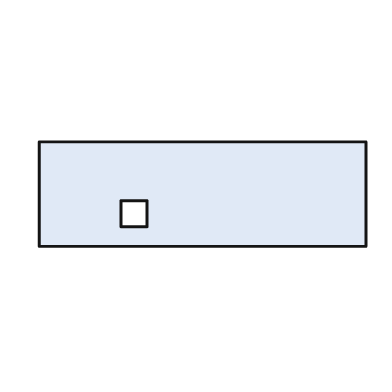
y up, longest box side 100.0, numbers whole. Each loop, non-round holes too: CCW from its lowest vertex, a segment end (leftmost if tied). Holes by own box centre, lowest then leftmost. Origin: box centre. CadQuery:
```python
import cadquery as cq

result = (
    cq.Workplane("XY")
    .moveTo(-50.0, -16.0)
    .lineTo(50.0, -16.0)
    .lineTo(50.0, 16.0)
    .lineTo(-50.0, 16.0)
    .close()
    .moveTo(-25.0, -10.0)
    .lineTo(-17.0, -10.0)
    .lineTo(-17.0, -2.0)
    .lineTo(-25.0, -2.0)
    .close()
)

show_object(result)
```